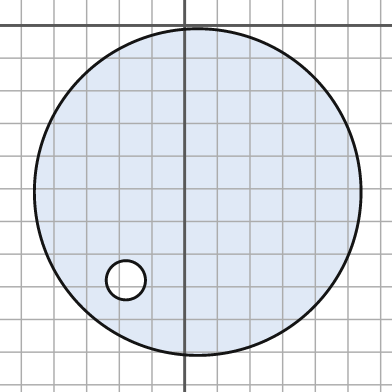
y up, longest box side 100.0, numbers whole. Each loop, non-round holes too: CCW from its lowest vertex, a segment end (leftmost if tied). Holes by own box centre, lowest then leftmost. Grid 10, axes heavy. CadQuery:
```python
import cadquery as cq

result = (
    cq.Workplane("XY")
    .moveTo(4.0, -51.0)
    .circle(50.0)
    .moveTo(-18.0, -78.0)
    .circle(6.0)
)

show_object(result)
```